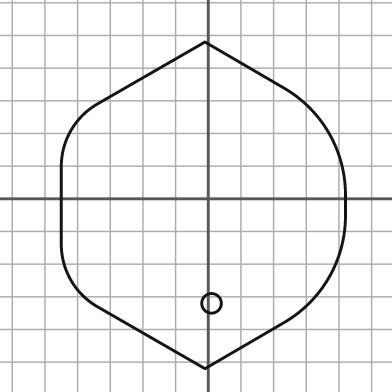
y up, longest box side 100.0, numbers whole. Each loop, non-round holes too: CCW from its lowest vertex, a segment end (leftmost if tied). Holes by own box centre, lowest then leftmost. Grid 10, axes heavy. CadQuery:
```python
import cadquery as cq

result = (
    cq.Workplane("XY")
    .moveTo(-1.0, -52.0)
    .lineTo(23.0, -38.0)
    .threePointArc((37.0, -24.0), (42.0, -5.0))
    .lineTo(42.0, 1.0)
    .threePointArc((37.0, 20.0), (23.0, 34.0))
    .lineTo(-1.0, 48.0)
    .lineTo(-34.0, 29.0)
    .threePointArc((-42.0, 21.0), (-45.0, 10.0))
    .lineTo(-45.0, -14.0)
    .threePointArc((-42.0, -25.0), (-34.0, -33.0))
    .close()
    .moveTo(1.0, -32.0)
    .circle(3.0)
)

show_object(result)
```